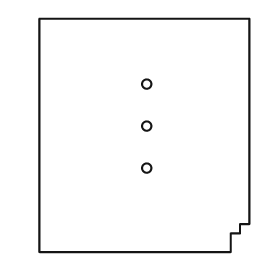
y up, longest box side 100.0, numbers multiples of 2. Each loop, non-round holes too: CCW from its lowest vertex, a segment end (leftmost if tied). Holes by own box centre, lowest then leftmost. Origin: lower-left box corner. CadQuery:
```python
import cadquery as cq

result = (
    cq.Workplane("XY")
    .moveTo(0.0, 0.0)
    .lineTo(82.0, 0.0)
    .lineTo(82.0, 8.0)
    .lineTo(86.0, 8.0)
    .lineTo(86.0, 12.0)
    .lineTo(90.0, 12.0)
    .lineTo(90.0, 100.0)
    .lineTo(0.0, 100.0)
    .close()
    .moveTo(46.0, 36.0)
    .circle(2.0)
    .moveTo(46.0, 54.0)
    .circle(2.0)
    .moveTo(46.0, 72.0)
    .circle(2.0)
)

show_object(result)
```